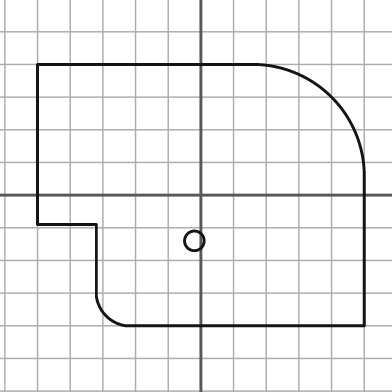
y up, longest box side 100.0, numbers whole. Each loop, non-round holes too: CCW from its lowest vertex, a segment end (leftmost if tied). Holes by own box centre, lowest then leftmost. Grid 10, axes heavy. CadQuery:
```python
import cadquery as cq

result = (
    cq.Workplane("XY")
    .moveTo(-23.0, -40.0)
    .lineTo(50.0, -40.0)
    .lineTo(50.0, 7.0)
    .threePointArc((40.0, 30.0), (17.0, 40.0))
    .lineTo(-50.0, 40.0)
    .lineTo(-50.0, -9.0)
    .lineTo(-32.0, -9.0)
    .lineTo(-32.0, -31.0)
    .threePointArc((-29.0, -37.0), (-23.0, -40.0))
    .close()
    .moveTo(-2.0, -14.0)
    .circle(3.0)
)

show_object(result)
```